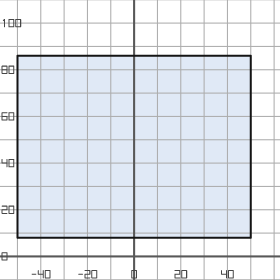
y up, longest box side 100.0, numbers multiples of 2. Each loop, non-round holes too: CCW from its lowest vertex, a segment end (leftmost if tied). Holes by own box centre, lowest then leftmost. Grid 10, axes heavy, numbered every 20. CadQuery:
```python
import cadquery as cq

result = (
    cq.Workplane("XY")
    .moveTo(-50.0, 8.0)
    .lineTo(50.0, 8.0)
    .lineTo(50.0, 86.0)
    .lineTo(-50.0, 86.0)
    .close()
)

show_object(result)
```